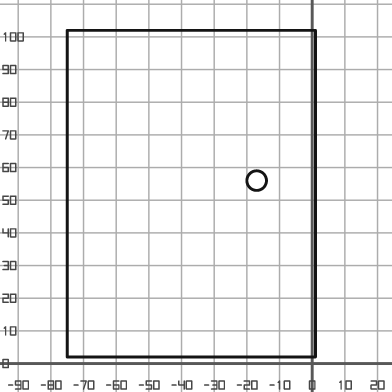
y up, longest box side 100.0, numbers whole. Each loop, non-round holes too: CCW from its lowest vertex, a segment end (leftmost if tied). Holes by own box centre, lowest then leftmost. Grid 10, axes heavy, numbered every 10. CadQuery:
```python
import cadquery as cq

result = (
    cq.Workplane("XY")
    .moveTo(-75.0, 2.0)
    .lineTo(1.0, 2.0)
    .lineTo(1.0, 102.0)
    .lineTo(-75.0, 102.0)
    .close()
    .moveTo(-17.0, 56.0)
    .circle(3.0)
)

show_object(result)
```